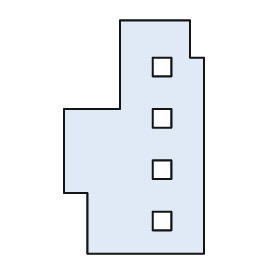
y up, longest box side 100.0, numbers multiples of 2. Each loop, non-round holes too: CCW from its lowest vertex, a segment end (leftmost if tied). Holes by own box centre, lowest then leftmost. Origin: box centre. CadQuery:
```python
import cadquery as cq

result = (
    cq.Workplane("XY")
    .moveTo(-20.0, -50.0)
    .lineTo(30.0, -50.0)
    .lineTo(30.0, 34.0)
    .lineTo(24.0, 34.0)
    .lineTo(24.0, 50.0)
    .lineTo(-6.0, 50.0)
    .lineTo(-6.0, 12.0)
    .lineTo(-30.0, 12.0)
    .lineTo(-30.0, -24.0)
    .lineTo(-20.0, -24.0)
    .close()
    .moveTo(8.0, -40.0)
    .lineTo(16.0, -40.0)
    .lineTo(16.0, -32.0)
    .lineTo(8.0, -32.0)
    .close()
    .moveTo(8.0, -18.0)
    .lineTo(16.0, -18.0)
    .lineTo(16.0, -10.0)
    .lineTo(8.0, -10.0)
    .close()
    .moveTo(8.0, 4.0)
    .lineTo(16.0, 4.0)
    .lineTo(16.0, 12.0)
    .lineTo(8.0, 12.0)
    .close()
    .moveTo(8.0, 26.0)
    .lineTo(16.0, 26.0)
    .lineTo(16.0, 34.0)
    .lineTo(8.0, 34.0)
    .close()
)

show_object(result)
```